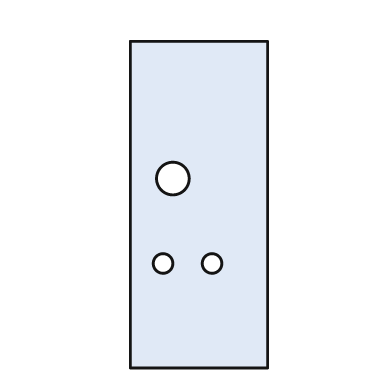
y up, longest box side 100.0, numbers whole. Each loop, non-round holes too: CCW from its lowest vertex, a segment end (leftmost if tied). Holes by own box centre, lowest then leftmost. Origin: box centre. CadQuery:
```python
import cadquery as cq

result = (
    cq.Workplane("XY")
    .moveTo(-21.0, -50.0)
    .lineTo(21.0, -50.0)
    .lineTo(21.0, 50.0)
    .lineTo(-21.0, 50.0)
    .close()
    .moveTo(-11.0, -18.0)
    .circle(3.0)
    .moveTo(4.0, -18.0)
    .circle(3.0)
    .moveTo(-8.0, 8.0)
    .circle(5.0)
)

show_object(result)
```